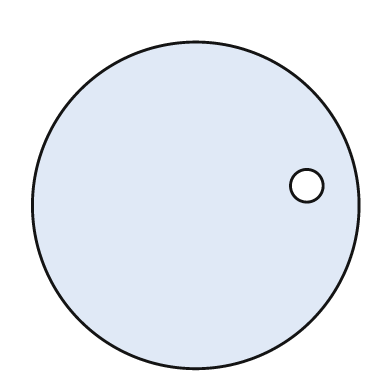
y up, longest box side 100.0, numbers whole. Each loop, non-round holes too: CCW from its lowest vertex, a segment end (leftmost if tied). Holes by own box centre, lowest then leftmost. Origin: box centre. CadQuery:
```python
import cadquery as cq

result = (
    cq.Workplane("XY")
    .moveTo(0.0, 0.0)
    .circle(50.0)
    .moveTo(34.0, 6.0)
    .circle(5.0)
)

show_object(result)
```